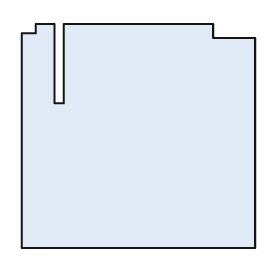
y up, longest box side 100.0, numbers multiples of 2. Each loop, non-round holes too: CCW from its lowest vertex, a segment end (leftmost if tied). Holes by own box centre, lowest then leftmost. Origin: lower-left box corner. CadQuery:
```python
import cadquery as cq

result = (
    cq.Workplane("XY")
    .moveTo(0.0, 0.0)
    .lineTo(100.0, 0.0)
    .lineTo(100.0, 90.0)
    .lineTo(82.0, 90.0)
    .lineTo(82.0, 96.0)
    .lineTo(18.0, 96.0)
    .lineTo(18.0, 62.0)
    .lineTo(14.0, 62.0)
    .lineTo(14.0, 96.0)
    .lineTo(6.0, 96.0)
    .lineTo(6.0, 92.0)
    .lineTo(0.0, 92.0)
    .close()
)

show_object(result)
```